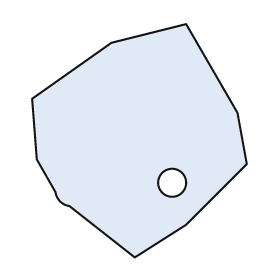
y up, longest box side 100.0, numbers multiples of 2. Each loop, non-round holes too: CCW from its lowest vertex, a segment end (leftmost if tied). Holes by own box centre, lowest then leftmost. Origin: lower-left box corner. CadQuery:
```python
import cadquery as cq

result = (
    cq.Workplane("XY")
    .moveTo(44.0, 0.0)
    .lineTo(66.0, 14.0)
    .lineTo(92.0, 40.0)
    .lineTo(88.0, 62.0)
    .lineTo(66.0, 100.0)
    .lineTo(34.0, 92.0)
    .lineTo(0.0, 68.0)
    .lineTo(2.0, 42.0)
    .lineTo(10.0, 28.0)
    .threePointArc((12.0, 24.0), (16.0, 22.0))
    .close()
    .moveTo(60.0, 32.0)
    .circle(6.0)
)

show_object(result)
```